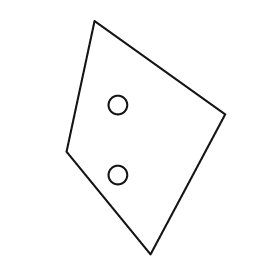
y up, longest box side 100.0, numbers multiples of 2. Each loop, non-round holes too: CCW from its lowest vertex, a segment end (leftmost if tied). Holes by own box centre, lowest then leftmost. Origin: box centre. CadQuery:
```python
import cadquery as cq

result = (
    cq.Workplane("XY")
    .moveTo(2.0, -50.0)
    .lineTo(34.0, 10.0)
    .lineTo(-22.0, 50.0)
    .lineTo(-34.0, -6.0)
    .close()
    .moveTo(-12.0, -16.0)
    .circle(4.0)
    .moveTo(-12.0, 14.0)
    .circle(4.0)
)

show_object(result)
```